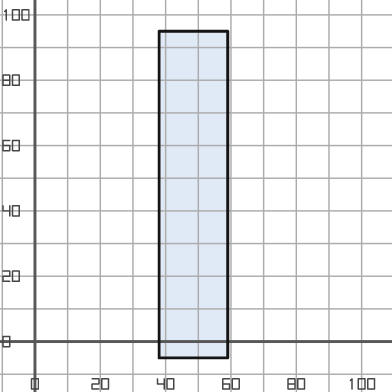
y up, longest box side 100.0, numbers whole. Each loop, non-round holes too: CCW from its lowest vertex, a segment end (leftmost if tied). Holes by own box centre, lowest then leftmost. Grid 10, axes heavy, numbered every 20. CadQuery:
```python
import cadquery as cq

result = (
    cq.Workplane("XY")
    .moveTo(38.0, -5.0)
    .lineTo(59.0, -5.0)
    .lineTo(59.0, 95.0)
    .lineTo(38.0, 95.0)
    .close()
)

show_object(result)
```